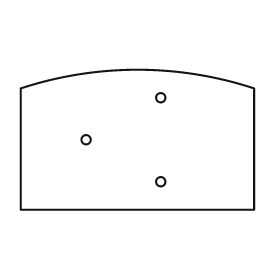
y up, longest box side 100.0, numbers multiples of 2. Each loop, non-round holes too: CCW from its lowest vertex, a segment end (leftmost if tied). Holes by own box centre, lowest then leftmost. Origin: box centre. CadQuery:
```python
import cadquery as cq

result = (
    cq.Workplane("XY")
    .moveTo(-50.0, -30.0)
    .lineTo(50.0, -30.0)
    .lineTo(50.0, 22.0)
    .threePointArc((0.0, 30.0), (-50.0, 22.0))
    .close()
    .moveTo(10.0, -18.0)
    .circle(2.0)
    .moveTo(-22.0, 0.0)
    .circle(2.0)
    .moveTo(10.0, 18.0)
    .circle(2.0)
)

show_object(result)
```